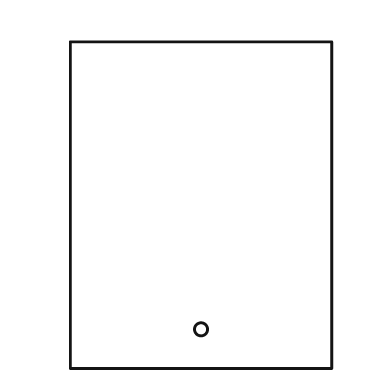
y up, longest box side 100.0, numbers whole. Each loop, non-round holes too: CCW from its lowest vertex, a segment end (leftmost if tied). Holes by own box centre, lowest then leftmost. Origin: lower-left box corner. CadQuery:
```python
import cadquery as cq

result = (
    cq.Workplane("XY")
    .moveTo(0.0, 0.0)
    .lineTo(80.0, 0.0)
    .lineTo(80.0, 100.0)
    .lineTo(0.0, 100.0)
    .close()
    .moveTo(40.0, 12.0)
    .circle(2.0)
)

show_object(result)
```